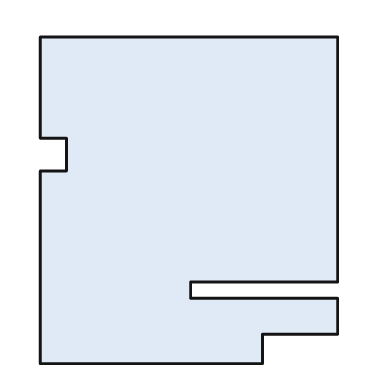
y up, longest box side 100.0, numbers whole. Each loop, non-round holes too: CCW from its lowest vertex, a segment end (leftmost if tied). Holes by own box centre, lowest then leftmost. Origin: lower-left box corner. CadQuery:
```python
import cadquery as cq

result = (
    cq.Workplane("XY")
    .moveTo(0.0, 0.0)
    .lineTo(68.0, 0.0)
    .lineTo(68.0, 9.0)
    .lineTo(91.0, 9.0)
    .lineTo(91.0, 20.0)
    .lineTo(46.0, 20.0)
    .lineTo(46.0, 25.0)
    .lineTo(91.0, 25.0)
    .lineTo(91.0, 100.0)
    .lineTo(0.0, 100.0)
    .lineTo(0.0, 69.0)
    .lineTo(8.0, 69.0)
    .lineTo(8.0, 59.0)
    .lineTo(0.0, 59.0)
    .close()
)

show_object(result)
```